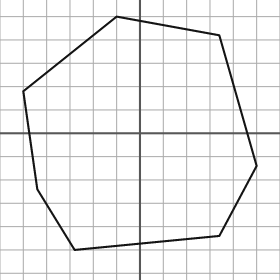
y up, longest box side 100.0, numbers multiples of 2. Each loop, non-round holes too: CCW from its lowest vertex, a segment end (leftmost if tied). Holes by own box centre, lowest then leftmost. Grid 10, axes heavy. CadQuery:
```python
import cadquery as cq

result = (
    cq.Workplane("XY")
    .moveTo(-28.0, -50.0)
    .lineTo(34.0, -44.0)
    .lineTo(50.0, -14.0)
    .lineTo(34.0, 42.0)
    .lineTo(-10.0, 50.0)
    .lineTo(-50.0, 18.0)
    .lineTo(-44.0, -24.0)
    .close()
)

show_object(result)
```